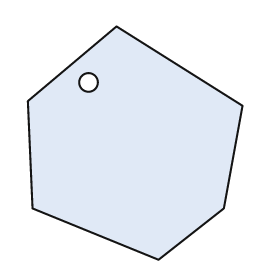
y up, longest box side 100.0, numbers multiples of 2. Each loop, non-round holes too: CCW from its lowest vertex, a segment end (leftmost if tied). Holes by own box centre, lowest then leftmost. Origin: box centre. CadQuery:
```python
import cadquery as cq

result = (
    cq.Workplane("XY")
    .moveTo(10.0, -50.0)
    .lineTo(38.0, -28.0)
    .lineTo(46.0, 16.0)
    .lineTo(-8.0, 50.0)
    .lineTo(-46.0, 18.0)
    .lineTo(-44.0, -28.0)
    .close()
    .moveTo(-20.0, 26.0)
    .circle(4.0)
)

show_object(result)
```